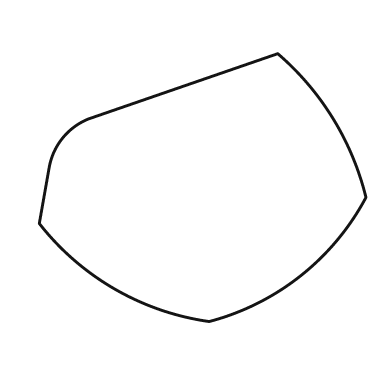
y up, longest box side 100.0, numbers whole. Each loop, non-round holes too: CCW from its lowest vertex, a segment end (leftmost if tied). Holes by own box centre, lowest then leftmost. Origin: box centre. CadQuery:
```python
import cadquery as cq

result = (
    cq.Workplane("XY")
    .moveTo(2.0, -41.0)
    .threePointArc((30.0, -27.0), (50.0, -3.0))
    .threePointArc((40.0, 21.0), (23.0, 41.0))
    .lineTo(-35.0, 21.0)
    .threePointArc((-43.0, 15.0), (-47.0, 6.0))
    .lineTo(-50.0, -11.0)
    .threePointArc((-27.0, -31.0), (2.0, -41.0))
    .close()
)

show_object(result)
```